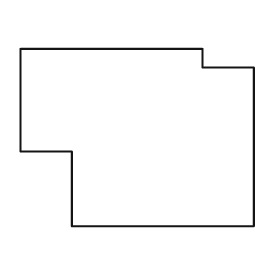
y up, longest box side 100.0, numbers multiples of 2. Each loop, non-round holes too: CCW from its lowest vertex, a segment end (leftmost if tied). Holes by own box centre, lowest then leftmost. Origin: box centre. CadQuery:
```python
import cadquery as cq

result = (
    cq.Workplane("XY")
    .moveTo(-28.0, -38.0)
    .lineTo(50.0, -38.0)
    .lineTo(50.0, 30.0)
    .lineTo(28.0, 30.0)
    .lineTo(28.0, 38.0)
    .lineTo(-50.0, 38.0)
    .lineTo(-50.0, -6.0)
    .lineTo(-28.0, -6.0)
    .close()
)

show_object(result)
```